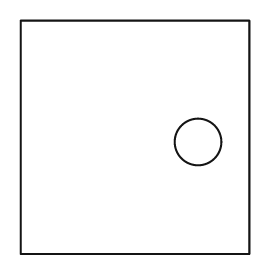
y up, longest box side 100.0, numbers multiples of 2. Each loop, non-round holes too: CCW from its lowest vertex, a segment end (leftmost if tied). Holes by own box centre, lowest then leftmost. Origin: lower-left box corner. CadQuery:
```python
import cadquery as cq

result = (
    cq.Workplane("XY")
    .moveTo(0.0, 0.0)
    .lineTo(98.0, 0.0)
    .lineTo(98.0, 100.0)
    .lineTo(0.0, 100.0)
    .close()
    .moveTo(76.0, 48.0)
    .circle(10.0)
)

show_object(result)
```